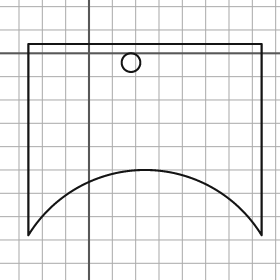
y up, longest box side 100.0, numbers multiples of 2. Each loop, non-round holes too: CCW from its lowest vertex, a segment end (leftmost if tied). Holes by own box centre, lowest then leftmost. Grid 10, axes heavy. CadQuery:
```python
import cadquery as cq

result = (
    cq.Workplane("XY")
    .moveTo(-26.0, -78.0)
    .threePointArc((24.0, -50.0), (74.0, -78.0))
    .lineTo(74.0, 4.0)
    .lineTo(-26.0, 4.0)
    .close()
    .moveTo(18.0, -4.0)
    .circle(4.0)
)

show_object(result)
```